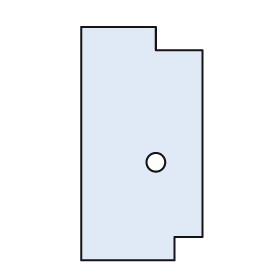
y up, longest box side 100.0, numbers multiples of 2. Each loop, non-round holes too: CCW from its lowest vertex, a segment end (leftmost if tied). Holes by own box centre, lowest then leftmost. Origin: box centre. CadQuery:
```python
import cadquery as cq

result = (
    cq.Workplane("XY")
    .moveTo(-26.0, -50.0)
    .lineTo(14.0, -50.0)
    .lineTo(14.0, -40.0)
    .lineTo(26.0, -40.0)
    .lineTo(26.0, 40.0)
    .lineTo(6.0, 40.0)
    .lineTo(6.0, 50.0)
    .lineTo(-26.0, 50.0)
    .close()
    .moveTo(6.0, -8.0)
    .circle(4.0)
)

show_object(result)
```